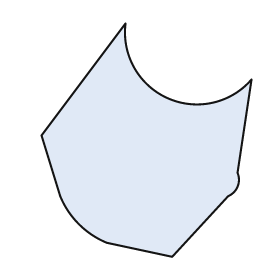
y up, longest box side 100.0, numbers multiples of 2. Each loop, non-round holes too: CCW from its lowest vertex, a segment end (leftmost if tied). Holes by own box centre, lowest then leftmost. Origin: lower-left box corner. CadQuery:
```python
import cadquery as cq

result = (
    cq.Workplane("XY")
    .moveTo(56.0, 0.0)
    .lineTo(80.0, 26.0)
    .threePointArc((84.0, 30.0), (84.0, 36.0))
    .lineTo(90.0, 76.0)
    .threePointArc((54.0, 68.0), (36.0, 100.0))
    .lineTo(0.0, 52.0)
    .lineTo(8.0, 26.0)
    .threePointArc((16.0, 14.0), (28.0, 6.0))
    .close()
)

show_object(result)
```